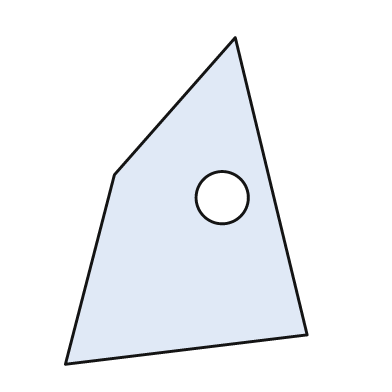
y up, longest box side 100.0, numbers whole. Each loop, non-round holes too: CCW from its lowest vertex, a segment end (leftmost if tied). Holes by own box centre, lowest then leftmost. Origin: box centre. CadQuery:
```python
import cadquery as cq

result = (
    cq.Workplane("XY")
    .moveTo(-37.0, -50.0)
    .lineTo(37.0, -41.0)
    .lineTo(15.0, 50.0)
    .lineTo(-22.0, 8.0)
    .close()
    .moveTo(11.0, 1.0)
    .circle(8.0)
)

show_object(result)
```